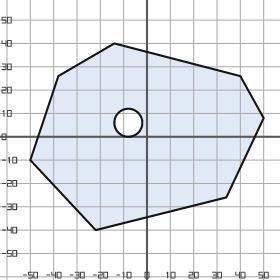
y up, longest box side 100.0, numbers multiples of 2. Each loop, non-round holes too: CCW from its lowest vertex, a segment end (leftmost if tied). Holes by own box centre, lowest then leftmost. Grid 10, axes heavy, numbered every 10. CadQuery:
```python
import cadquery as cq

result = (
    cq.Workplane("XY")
    .moveTo(-22.0, -40.0)
    .lineTo(34.0, -26.0)
    .lineTo(50.0, 8.0)
    .lineTo(40.0, 26.0)
    .lineTo(-14.0, 40.0)
    .lineTo(-38.0, 26.0)
    .lineTo(-50.0, -10.0)
    .close()
    .moveTo(-8.0, 6.0)
    .circle(6.0)
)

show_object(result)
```